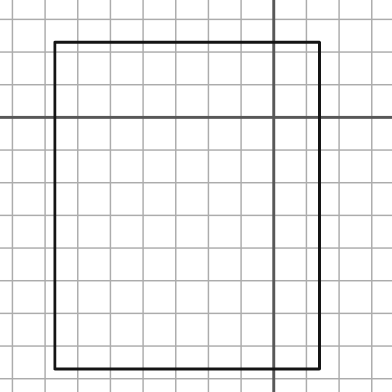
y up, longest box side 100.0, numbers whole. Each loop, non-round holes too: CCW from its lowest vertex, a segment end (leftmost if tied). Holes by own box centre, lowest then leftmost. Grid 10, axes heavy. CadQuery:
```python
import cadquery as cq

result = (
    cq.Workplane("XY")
    .moveTo(-67.0, -77.0)
    .lineTo(14.0, -77.0)
    .lineTo(14.0, 23.0)
    .lineTo(-67.0, 23.0)
    .close()
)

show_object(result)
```